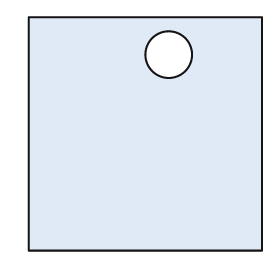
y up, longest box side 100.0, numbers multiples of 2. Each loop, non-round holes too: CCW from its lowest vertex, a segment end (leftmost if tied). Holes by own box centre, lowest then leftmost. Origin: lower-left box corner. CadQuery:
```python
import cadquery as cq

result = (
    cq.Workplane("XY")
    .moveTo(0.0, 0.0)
    .lineTo(100.0, 0.0)
    .lineTo(100.0, 100.0)
    .lineTo(0.0, 100.0)
    .close()
    .moveTo(60.0, 84.0)
    .circle(10.0)
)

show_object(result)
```